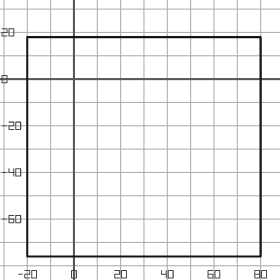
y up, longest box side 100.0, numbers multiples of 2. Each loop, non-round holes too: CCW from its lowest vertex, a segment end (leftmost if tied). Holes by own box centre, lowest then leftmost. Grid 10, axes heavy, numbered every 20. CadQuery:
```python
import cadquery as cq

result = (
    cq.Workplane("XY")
    .moveTo(-20.0, -76.0)
    .lineTo(80.0, -76.0)
    .lineTo(80.0, 18.0)
    .lineTo(-20.0, 18.0)
    .close()
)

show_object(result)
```